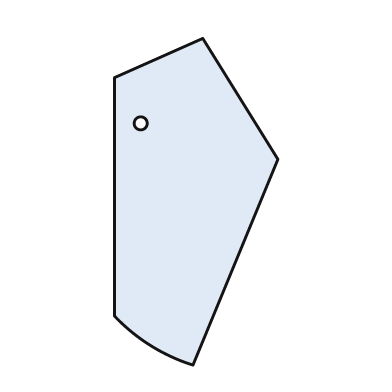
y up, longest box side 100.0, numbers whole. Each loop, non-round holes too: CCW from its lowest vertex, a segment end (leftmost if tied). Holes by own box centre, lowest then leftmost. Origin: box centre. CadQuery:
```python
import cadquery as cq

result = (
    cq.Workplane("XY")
    .moveTo(-1.0, -50.0)
    .lineTo(25.0, 13.0)
    .lineTo(2.0, 50.0)
    .lineTo(-25.0, 38.0)
    .lineTo(-25.0, -35.0)
    .threePointArc((-14.0, -44.0), (-1.0, -50.0))
    .close()
    .moveTo(-17.0, 24.0)
    .circle(2.0)
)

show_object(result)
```